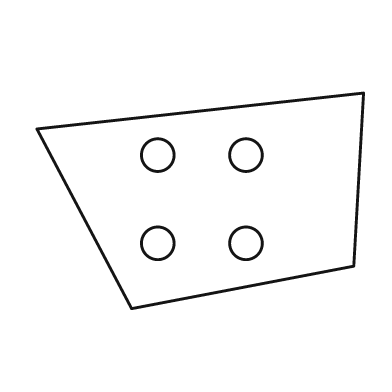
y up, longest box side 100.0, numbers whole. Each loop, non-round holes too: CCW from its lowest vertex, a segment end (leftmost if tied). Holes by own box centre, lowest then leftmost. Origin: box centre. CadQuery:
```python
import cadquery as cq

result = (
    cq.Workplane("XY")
    .moveTo(-21.0, -33.0)
    .lineTo(47.0, -20.0)
    .lineTo(50.0, 33.0)
    .lineTo(-50.0, 22.0)
    .close()
    .moveTo(-13.0, -13.0)
    .circle(5.0)
    .moveTo(14.0, -13.0)
    .circle(5.0)
    .moveTo(-13.0, 14.0)
    .circle(5.0)
    .moveTo(14.0, 14.0)
    .circle(5.0)
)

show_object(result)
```